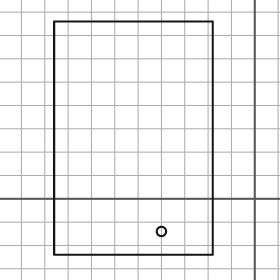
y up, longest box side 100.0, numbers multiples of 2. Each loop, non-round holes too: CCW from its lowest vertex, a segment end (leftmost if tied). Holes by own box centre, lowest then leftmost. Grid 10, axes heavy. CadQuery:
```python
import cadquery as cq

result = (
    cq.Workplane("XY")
    .moveTo(-86.0, -24.0)
    .lineTo(-18.0, -24.0)
    .lineTo(-18.0, 76.0)
    .lineTo(-86.0, 76.0)
    .close()
    .moveTo(-40.0, -14.0)
    .circle(2.0)
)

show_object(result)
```